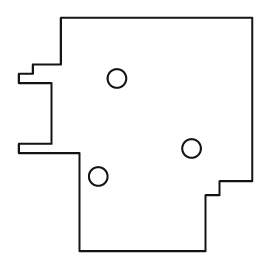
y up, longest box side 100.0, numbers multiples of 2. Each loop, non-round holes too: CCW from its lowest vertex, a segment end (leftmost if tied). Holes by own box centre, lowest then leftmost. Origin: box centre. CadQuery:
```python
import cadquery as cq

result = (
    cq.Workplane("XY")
    .moveTo(-24.0, -50.0)
    .lineTo(30.0, -50.0)
    .lineTo(30.0, -26.0)
    .lineTo(36.0, -26.0)
    .lineTo(36.0, -20.0)
    .lineTo(50.0, -20.0)
    .lineTo(50.0, 50.0)
    .lineTo(-32.0, 50.0)
    .lineTo(-32.0, 30.0)
    .lineTo(-44.0, 30.0)
    .lineTo(-44.0, 26.0)
    .lineTo(-50.0, 26.0)
    .lineTo(-50.0, 22.0)
    .lineTo(-36.0, 22.0)
    .lineTo(-36.0, -4.0)
    .lineTo(-50.0, -4.0)
    .lineTo(-50.0, -8.0)
    .lineTo(-24.0, -8.0)
    .close()
    .moveTo(-16.0, -18.0)
    .circle(4.0)
    .moveTo(24.0, -6.0)
    .circle(4.0)
    .moveTo(-8.0, 24.0)
    .circle(4.0)
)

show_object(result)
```